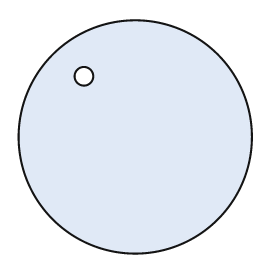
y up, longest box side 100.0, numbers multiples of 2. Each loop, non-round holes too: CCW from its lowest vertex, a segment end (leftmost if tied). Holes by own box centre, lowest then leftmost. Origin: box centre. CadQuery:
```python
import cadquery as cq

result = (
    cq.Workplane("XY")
    .moveTo(0.0, 0.0)
    .circle(50.0)
    .moveTo(-22.0, 26.0)
    .circle(4.0)
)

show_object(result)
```